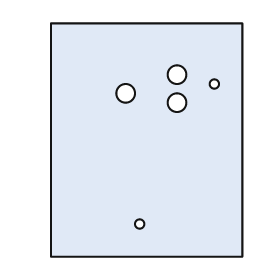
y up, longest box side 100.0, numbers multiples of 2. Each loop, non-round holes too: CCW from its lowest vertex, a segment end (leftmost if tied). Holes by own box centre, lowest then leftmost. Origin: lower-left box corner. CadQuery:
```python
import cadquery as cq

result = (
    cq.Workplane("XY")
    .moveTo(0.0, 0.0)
    .lineTo(82.0, 0.0)
    .lineTo(82.0, 100.0)
    .lineTo(0.0, 100.0)
    .close()
    .moveTo(38.0, 14.0)
    .circle(2.0)
    .moveTo(54.0, 66.0)
    .circle(4.0)
    .moveTo(32.0, 70.0)
    .circle(4.0)
    .moveTo(70.0, 74.0)
    .circle(2.0)
    .moveTo(54.0, 78.0)
    .circle(4.0)
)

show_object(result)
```